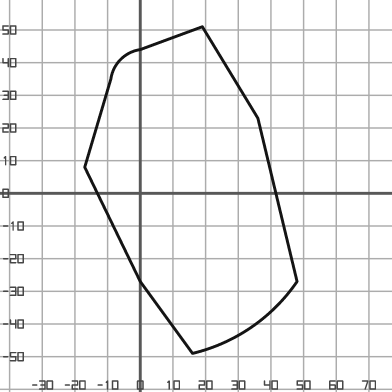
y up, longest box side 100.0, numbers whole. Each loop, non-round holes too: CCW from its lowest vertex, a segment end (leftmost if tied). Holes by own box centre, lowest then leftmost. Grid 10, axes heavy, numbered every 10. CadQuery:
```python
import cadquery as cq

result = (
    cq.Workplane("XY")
    .moveTo(16.0, -49.0)
    .threePointArc((34.0, -41.0), (48.0, -27.0))
    .lineTo(36.0, 23.0)
    .lineTo(19.0, 51.0)
    .lineTo(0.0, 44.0)
    .threePointArc((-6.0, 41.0), (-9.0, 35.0))
    .lineTo(-17.0, 8.0)
    .lineTo(0.0, -27.0)
    .close()
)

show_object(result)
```